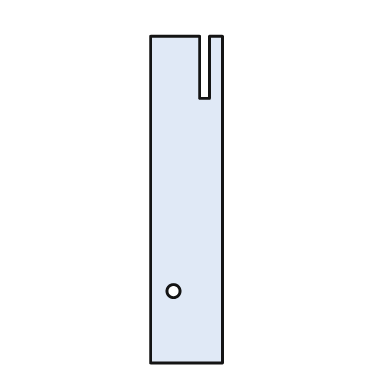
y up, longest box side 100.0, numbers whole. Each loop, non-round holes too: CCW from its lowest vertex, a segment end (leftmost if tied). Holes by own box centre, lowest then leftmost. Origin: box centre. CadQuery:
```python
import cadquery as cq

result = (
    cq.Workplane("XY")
    .moveTo(-11.0, -50.0)
    .lineTo(11.0, -50.0)
    .lineTo(11.0, 50.0)
    .lineTo(7.0, 50.0)
    .lineTo(7.0, 31.0)
    .lineTo(4.0, 31.0)
    .lineTo(4.0, 50.0)
    .lineTo(-11.0, 50.0)
    .close()
    .moveTo(-4.0, -28.0)
    .circle(2.0)
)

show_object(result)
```